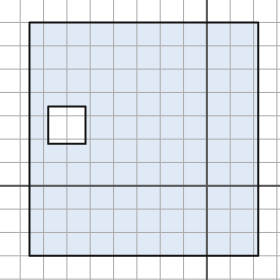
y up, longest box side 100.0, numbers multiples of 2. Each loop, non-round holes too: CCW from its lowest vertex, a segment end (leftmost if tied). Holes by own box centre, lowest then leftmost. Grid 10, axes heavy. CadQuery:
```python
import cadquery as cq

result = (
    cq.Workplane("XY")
    .moveTo(-76.0, -30.0)
    .lineTo(22.0, -30.0)
    .lineTo(22.0, 70.0)
    .lineTo(-76.0, 70.0)
    .close()
    .moveTo(-68.0, 18.0)
    .lineTo(-52.0, 18.0)
    .lineTo(-52.0, 34.0)
    .lineTo(-68.0, 34.0)
    .close()
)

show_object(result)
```